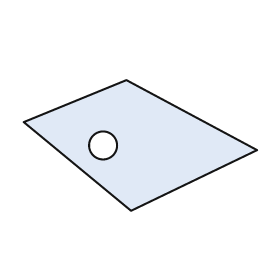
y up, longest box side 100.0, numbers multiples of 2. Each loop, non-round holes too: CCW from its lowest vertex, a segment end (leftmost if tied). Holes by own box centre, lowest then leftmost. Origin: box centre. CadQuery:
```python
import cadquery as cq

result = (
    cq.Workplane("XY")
    .moveTo(-4.0, -28.0)
    .lineTo(50.0, -2.0)
    .lineTo(-6.0, 28.0)
    .lineTo(-50.0, 10.0)
    .close()
    .moveTo(-16.0, 0.0)
    .circle(6.0)
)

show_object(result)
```